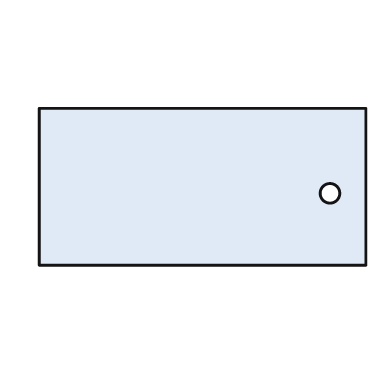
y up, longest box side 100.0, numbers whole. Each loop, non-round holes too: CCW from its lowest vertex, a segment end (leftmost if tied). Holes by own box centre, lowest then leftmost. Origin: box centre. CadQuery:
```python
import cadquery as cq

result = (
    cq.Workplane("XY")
    .moveTo(-50.0, -24.0)
    .lineTo(50.0, -24.0)
    .lineTo(50.0, 24.0)
    .lineTo(-50.0, 24.0)
    .close()
    .moveTo(39.0, -2.0)
    .circle(3.0)
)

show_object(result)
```